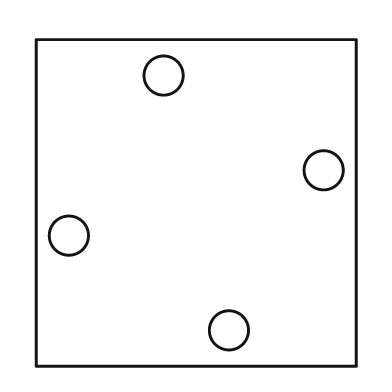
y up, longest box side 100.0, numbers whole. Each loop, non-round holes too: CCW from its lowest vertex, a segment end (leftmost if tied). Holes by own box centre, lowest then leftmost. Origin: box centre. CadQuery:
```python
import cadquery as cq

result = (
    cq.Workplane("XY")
    .moveTo(-49.0, -50.0)
    .lineTo(49.0, -50.0)
    .lineTo(49.0, 50.0)
    .lineTo(-49.0, 50.0)
    .close()
    .moveTo(10.0, -39.0)
    .circle(6.0)
    .moveTo(-39.0, -10.0)
    .circle(6.0)
    .moveTo(39.0, 10.0)
    .circle(6.0)
    .moveTo(-10.0, 39.0)
    .circle(6.0)
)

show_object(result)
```